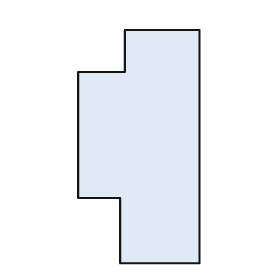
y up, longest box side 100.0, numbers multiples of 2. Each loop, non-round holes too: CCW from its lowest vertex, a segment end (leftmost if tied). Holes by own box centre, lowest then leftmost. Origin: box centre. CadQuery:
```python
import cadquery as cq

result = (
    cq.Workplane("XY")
    .moveTo(-8.0, -50.0)
    .lineTo(26.0, -50.0)
    .lineTo(26.0, 50.0)
    .lineTo(-6.0, 50.0)
    .lineTo(-6.0, 32.0)
    .lineTo(-26.0, 32.0)
    .lineTo(-26.0, -22.0)
    .lineTo(-8.0, -22.0)
    .close()
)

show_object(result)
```